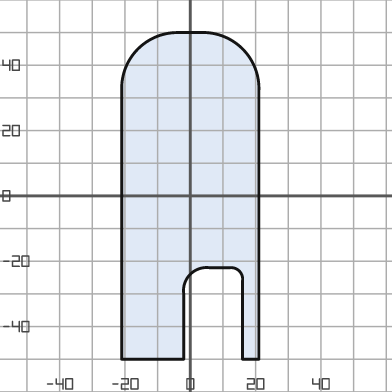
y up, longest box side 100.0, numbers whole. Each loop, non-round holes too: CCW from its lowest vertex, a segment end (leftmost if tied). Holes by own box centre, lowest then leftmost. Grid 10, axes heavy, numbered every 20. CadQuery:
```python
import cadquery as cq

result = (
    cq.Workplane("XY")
    .moveTo(-21.0, -50.0)
    .lineTo(-2.0, -50.0)
    .lineTo(-2.0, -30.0)
    .threePointArc((0.0, -24.0), (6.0, -22.0))
    .lineTo(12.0, -22.0)
    .threePointArc((15.0, -23.0), (16.0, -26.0))
    .lineTo(16.0, -50.0)
    .lineTo(21.0, -50.0)
    .lineTo(21.0, 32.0)
    .threePointArc((16.0, 45.0), (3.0, 50.0))
    .lineTo(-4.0, 50.0)
    .threePointArc((-16.0, 45.0), (-21.0, 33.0))
    .close()
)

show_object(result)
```